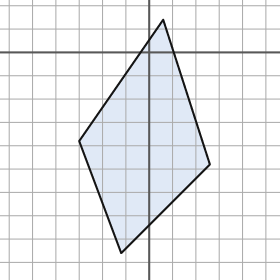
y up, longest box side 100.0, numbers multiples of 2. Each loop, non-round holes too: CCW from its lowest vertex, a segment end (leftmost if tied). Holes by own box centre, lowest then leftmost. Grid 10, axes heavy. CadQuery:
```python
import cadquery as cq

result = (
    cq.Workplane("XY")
    .moveTo(-12.0, -86.0)
    .lineTo(26.0, -48.0)
    .lineTo(6.0, 14.0)
    .lineTo(-30.0, -38.0)
    .close()
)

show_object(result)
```